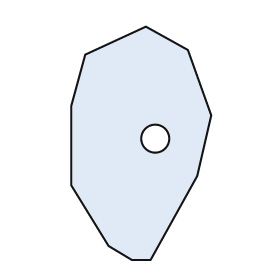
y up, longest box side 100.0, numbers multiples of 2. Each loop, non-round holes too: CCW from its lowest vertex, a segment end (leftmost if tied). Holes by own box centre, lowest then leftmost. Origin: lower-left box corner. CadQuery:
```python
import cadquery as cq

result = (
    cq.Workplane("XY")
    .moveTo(26.0, 0.0)
    .lineTo(34.0, 0.0)
    .lineTo(54.0, 36.0)
    .lineTo(60.0, 62.0)
    .lineTo(50.0, 90.0)
    .lineTo(32.0, 100.0)
    .lineTo(6.0, 88.0)
    .lineTo(0.0, 66.0)
    .lineTo(0.0, 32.0)
    .lineTo(16.0, 6.0)
    .close()
    .moveTo(36.0, 52.0)
    .circle(6.0)
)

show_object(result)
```